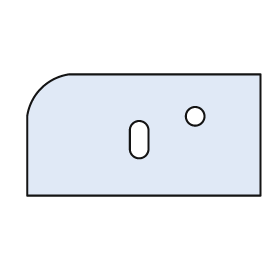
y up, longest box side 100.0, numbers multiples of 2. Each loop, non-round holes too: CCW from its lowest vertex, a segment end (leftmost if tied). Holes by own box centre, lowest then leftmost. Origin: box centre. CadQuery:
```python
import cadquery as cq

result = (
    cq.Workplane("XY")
    .moveTo(-50.0, -26.0)
    .lineTo(50.0, -26.0)
    .lineTo(50.0, 26.0)
    .lineTo(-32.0, 26.0)
    .threePointArc((-44.0, 20.0), (-50.0, 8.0))
    .close()
    .moveTo(-6.0, -6.0)
    .threePointArc((-2.0, -10.0), (2.0, -6.0))
    .lineTo(2.0, 2.0)
    .threePointArc((-2.0, 6.0), (-6.0, 2.0))
    .close()
    .moveTo(22.0, 8.0)
    .circle(4.0)
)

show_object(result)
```